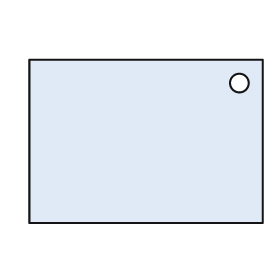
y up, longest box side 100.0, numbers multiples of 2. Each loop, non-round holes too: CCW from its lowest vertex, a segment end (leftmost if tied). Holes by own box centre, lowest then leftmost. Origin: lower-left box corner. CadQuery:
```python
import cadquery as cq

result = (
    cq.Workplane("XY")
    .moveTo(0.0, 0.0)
    .lineTo(100.0, 0.0)
    .lineTo(100.0, 70.0)
    .lineTo(0.0, 70.0)
    .close()
    .moveTo(90.0, 60.0)
    .circle(4.0)
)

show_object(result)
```